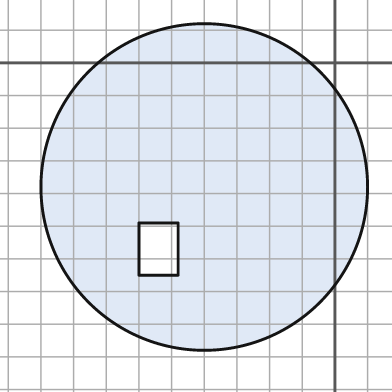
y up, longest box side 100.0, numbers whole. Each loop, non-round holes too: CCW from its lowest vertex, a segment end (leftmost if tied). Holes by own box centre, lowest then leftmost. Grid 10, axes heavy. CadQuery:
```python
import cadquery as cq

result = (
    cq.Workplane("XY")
    .moveTo(-40.0, -38.0)
    .circle(50.0)
    .moveTo(-60.0, -65.0)
    .lineTo(-48.0, -65.0)
    .lineTo(-48.0, -49.0)
    .lineTo(-60.0, -49.0)
    .close()
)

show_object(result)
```